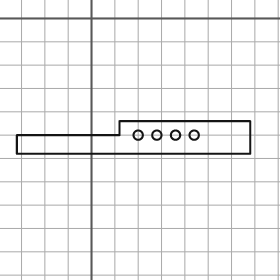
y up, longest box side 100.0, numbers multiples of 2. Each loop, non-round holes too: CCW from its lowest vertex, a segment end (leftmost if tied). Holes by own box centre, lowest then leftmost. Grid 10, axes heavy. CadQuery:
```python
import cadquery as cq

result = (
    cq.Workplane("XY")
    .moveTo(-32.0, -58.0)
    .lineTo(68.0, -58.0)
    .lineTo(68.0, -44.0)
    .lineTo(12.0, -44.0)
    .lineTo(12.0, -50.0)
    .lineTo(-32.0, -50.0)
    .close()
    .moveTo(20.0, -50.0)
    .circle(2.0)
    .moveTo(28.0, -50.0)
    .circle(2.0)
    .moveTo(36.0, -50.0)
    .circle(2.0)
    .moveTo(44.0, -50.0)
    .circle(2.0)
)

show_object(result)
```